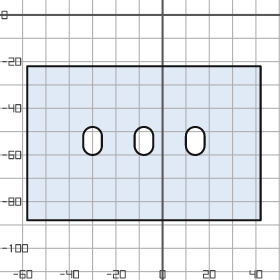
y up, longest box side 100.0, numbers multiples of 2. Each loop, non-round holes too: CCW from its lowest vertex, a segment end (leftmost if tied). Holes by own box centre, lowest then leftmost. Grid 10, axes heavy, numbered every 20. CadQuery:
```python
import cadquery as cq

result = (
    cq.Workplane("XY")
    .moveTo(-58.0, -88.0)
    .lineTo(42.0, -88.0)
    .lineTo(42.0, -22.0)
    .lineTo(-58.0, -22.0)
    .close()
    .moveTo(-34.0, -56.0)
    .threePointArc((-30.0, -60.0), (-26.0, -56.0))
    .lineTo(-26.0, -52.0)
    .threePointArc((-30.0, -48.0), (-34.0, -52.0))
    .close()
    .moveTo(-12.0, -56.0)
    .threePointArc((-8.0, -60.0), (-4.0, -56.0))
    .lineTo(-4.0, -52.0)
    .threePointArc((-8.0, -48.0), (-12.0, -52.0))
    .close()
    .moveTo(10.0, -56.0)
    .threePointArc((14.0, -60.0), (18.0, -56.0))
    .lineTo(18.0, -52.0)
    .threePointArc((14.0, -48.0), (10.0, -52.0))
    .close()
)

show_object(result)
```